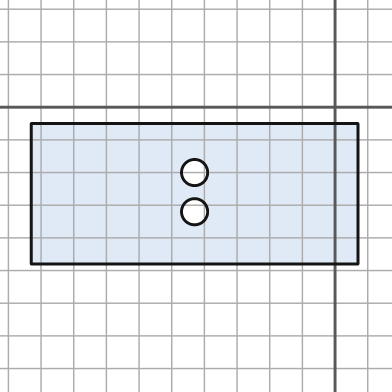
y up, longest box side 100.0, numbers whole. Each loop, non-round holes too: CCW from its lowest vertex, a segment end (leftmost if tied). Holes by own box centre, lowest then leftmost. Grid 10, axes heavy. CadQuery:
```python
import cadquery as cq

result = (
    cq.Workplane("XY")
    .moveTo(-93.0, -48.0)
    .lineTo(7.0, -48.0)
    .lineTo(7.0, -5.0)
    .lineTo(-93.0, -5.0)
    .close()
    .moveTo(-43.0, -32.0)
    .circle(4.0)
    .moveTo(-43.0, -20.0)
    .circle(4.0)
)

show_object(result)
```